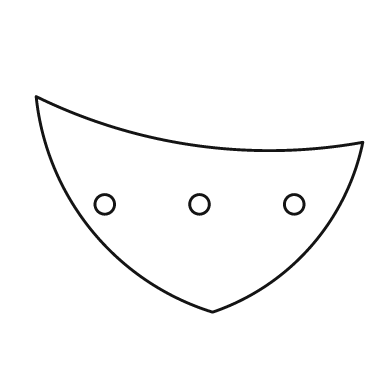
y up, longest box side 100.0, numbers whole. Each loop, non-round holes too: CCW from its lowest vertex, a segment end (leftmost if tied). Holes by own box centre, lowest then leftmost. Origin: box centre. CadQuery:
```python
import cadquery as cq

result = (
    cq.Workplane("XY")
    .moveTo(4.0, -33.0)
    .threePointArc((34.0, -13.0), (50.0, 19.0))
    .threePointArc((-1.0, 18.0), (-50.0, 33.0))
    .threePointArc((-33.0, -8.0), (4.0, -33.0))
    .close()
    .moveTo(-29.0, 0.0)
    .circle(3.0)
    .moveTo(0.0, 0.0)
    .circle(3.0)
    .moveTo(29.0, 0.0)
    .circle(3.0)
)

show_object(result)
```